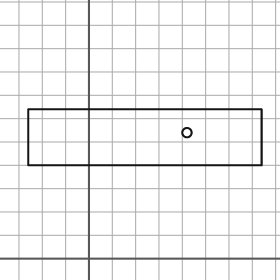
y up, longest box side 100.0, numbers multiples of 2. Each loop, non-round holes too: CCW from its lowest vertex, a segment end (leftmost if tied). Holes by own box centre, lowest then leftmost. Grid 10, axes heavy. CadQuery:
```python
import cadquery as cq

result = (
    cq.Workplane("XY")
    .moveTo(-26.0, 40.0)
    .lineTo(74.0, 40.0)
    .lineTo(74.0, 64.0)
    .lineTo(-26.0, 64.0)
    .close()
    .moveTo(42.0, 54.0)
    .circle(2.0)
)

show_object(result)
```